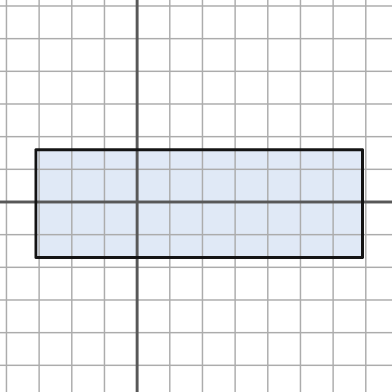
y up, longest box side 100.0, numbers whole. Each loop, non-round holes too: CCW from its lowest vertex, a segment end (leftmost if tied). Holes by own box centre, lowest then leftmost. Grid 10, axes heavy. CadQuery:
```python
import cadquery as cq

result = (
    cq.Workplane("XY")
    .moveTo(-31.0, -17.0)
    .lineTo(69.0, -17.0)
    .lineTo(69.0, 16.0)
    .lineTo(-31.0, 16.0)
    .close()
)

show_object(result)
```